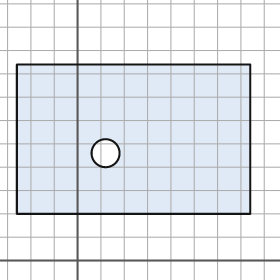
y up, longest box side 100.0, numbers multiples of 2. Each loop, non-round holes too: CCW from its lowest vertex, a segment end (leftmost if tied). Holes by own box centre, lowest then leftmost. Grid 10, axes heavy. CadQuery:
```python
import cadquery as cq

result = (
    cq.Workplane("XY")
    .moveTo(-26.0, 20.0)
    .lineTo(74.0, 20.0)
    .lineTo(74.0, 84.0)
    .lineTo(-26.0, 84.0)
    .close()
    .moveTo(12.0, 46.0)
    .circle(6.0)
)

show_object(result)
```